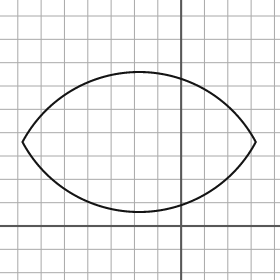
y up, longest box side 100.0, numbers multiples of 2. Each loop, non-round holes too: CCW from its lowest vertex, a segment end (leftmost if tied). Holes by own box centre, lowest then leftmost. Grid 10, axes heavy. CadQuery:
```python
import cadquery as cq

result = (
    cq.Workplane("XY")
    .moveTo(-68.0, 36.0)
    .threePointArc((-18.0, 6.0), (32.0, 36.0))
    .threePointArc((-18.0, 66.0), (-68.0, 36.0))
    .close()
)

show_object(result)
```